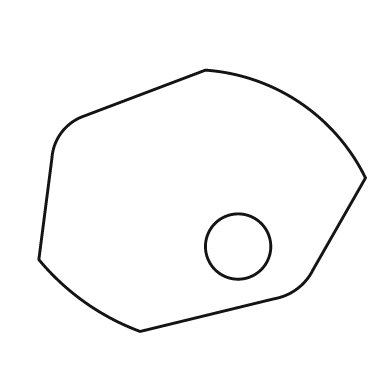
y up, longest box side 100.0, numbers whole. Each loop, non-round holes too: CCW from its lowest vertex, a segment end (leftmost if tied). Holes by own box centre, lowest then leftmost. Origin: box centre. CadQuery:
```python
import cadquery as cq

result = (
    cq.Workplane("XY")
    .moveTo(-19.0, -40.0)
    .lineTo(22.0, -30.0)
    .threePointArc((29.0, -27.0), (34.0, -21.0))
    .lineTo(50.0, 7.0)
    .threePointArc((30.0, 30.0), (1.0, 40.0))
    .lineTo(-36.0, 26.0)
    .threePointArc((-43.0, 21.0), (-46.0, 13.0))
    .lineTo(-50.0, -18.0)
    .threePointArc((-36.0, -31.0), (-19.0, -40.0))
    .close()
    .moveTo(11.0, -14.0)
    .circle(10.0)
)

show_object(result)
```